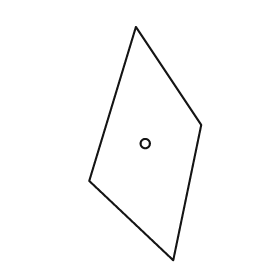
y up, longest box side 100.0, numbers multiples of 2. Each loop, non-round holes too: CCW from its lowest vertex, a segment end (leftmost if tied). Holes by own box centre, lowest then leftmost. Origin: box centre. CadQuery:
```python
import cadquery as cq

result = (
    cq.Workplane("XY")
    .moveTo(12.0, -50.0)
    .lineTo(24.0, 8.0)
    .lineTo(-4.0, 50.0)
    .lineTo(-24.0, -16.0)
    .close()
    .moveTo(0.0, 0.0)
    .circle(2.0)
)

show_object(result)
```